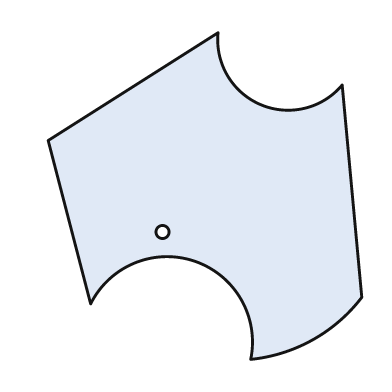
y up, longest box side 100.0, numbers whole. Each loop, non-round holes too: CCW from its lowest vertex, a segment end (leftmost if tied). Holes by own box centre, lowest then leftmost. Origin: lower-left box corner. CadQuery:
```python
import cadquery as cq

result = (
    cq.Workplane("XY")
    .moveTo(62.0, 0.0)
    .threePointArc((81.0, 6.0), (96.0, 19.0))
    .lineTo(90.0, 84.0)
    .threePointArc((65.0, 78.0), (52.0, 100.0))
    .lineTo(0.0, 67.0)
    .lineTo(13.0, 17.0)
    .threePointArc((45.0, 30.0), (62.0, 0.0))
    .close()
    .moveTo(35.0, 39.0)
    .circle(2.0)
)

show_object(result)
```